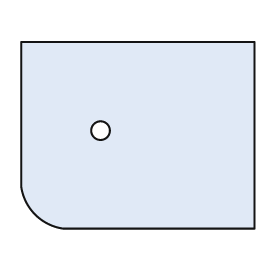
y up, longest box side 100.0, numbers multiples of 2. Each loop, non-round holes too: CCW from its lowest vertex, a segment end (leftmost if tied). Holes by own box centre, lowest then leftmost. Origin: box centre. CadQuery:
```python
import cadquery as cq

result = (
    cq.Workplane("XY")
    .moveTo(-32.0, -40.0)
    .lineTo(50.0, -40.0)
    .lineTo(50.0, 40.0)
    .lineTo(-50.0, 40.0)
    .lineTo(-50.0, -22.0)
    .threePointArc((-44.0, -34.0), (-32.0, -40.0))
    .close()
    .moveTo(-16.0, 2.0)
    .circle(4.0)
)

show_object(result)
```